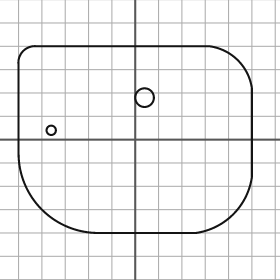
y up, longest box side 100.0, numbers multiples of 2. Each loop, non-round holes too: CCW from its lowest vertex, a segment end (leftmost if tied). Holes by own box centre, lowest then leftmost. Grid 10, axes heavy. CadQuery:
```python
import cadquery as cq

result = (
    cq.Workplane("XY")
    .moveTo(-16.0, -40.0)
    .lineTo(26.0, -40.0)
    .threePointArc((42.0, -32.0), (50.0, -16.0))
    .lineTo(50.0, 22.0)
    .threePointArc((44.0, 34.0), (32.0, 40.0))
    .lineTo(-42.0, 40.0)
    .threePointArc((-48.0, 38.0), (-50.0, 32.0))
    .lineTo(-50.0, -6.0)
    .threePointArc((-40.0, -30.0), (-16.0, -40.0))
    .close()
    .moveTo(-36.0, 4.0)
    .circle(2.0)
    .moveTo(4.0, 18.0)
    .circle(4.0)
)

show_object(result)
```